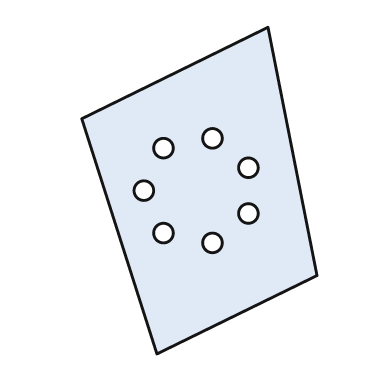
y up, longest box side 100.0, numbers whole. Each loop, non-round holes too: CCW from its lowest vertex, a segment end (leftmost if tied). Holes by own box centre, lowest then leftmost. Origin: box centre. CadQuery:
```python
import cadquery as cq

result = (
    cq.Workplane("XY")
    .moveTo(-13.0, -50.0)
    .lineTo(36.0, -26.0)
    .lineTo(21.0, 50.0)
    .lineTo(-36.0, 22.0)
    .close()
    .moveTo(4.0, -16.0)
    .circle(3.0)
    .moveTo(-11.0, -13.0)
    .circle(3.0)
    .moveTo(15.0, -7.0)
    .circle(3.0)
    .moveTo(-17.0, 0.0)
    .circle(3.0)
    .moveTo(15.0, 7.0)
    .circle(3.0)
    .moveTo(-11.0, 13.0)
    .circle(3.0)
    .moveTo(4.0, 16.0)
    .circle(3.0)
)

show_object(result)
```